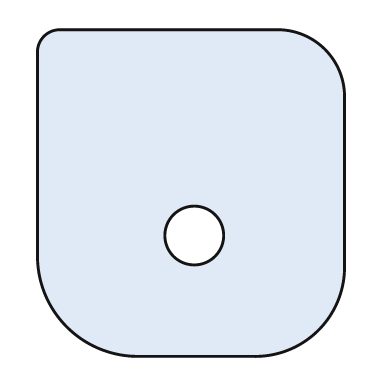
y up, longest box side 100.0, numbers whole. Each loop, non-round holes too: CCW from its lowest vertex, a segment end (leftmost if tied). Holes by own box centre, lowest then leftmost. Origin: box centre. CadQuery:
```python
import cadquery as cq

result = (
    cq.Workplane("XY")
    .moveTo(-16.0, -50.0)
    .lineTo(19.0, -50.0)
    .threePointArc((39.0, -42.0), (47.0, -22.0))
    .lineTo(47.0, 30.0)
    .threePointArc((41.0, 44.0), (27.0, 50.0))
    .lineTo(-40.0, 50.0)
    .threePointArc((-45.0, 48.0), (-47.0, 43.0))
    .lineTo(-47.0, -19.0)
    .threePointArc((-38.0, -41.0), (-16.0, -50.0))
    .close()
    .moveTo(1.0, -13.0)
    .circle(9.0)
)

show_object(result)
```